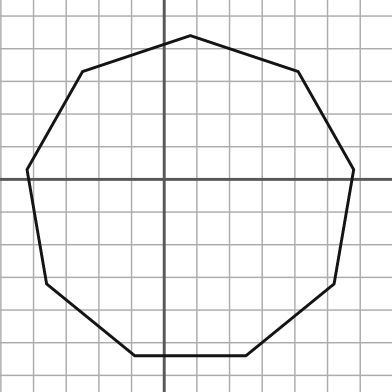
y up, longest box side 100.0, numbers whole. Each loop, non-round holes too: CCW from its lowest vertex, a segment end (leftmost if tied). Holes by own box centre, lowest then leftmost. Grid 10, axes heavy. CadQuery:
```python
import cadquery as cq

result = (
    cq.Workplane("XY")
    .moveTo(-9.0, -54.0)
    .lineTo(25.0, -54.0)
    .lineTo(52.0, -32.0)
    .lineTo(58.0, 3.0)
    .lineTo(41.0, 33.0)
    .lineTo(8.0, 44.0)
    .lineTo(-25.0, 33.0)
    .lineTo(-42.0, 3.0)
    .lineTo(-36.0, -32.0)
    .close()
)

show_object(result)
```